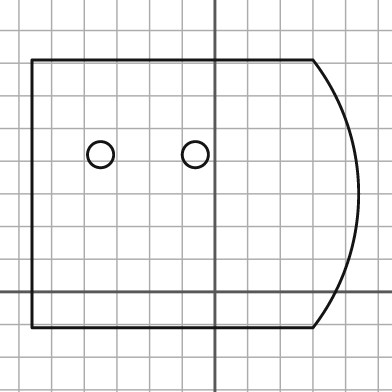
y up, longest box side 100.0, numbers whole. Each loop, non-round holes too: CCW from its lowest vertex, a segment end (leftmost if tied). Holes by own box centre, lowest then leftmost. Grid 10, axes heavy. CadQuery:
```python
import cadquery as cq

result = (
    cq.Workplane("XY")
    .moveTo(-56.0, -11.0)
    .lineTo(30.0, -11.0)
    .threePointArc((44.0, 30.0), (30.0, 71.0))
    .lineTo(-56.0, 71.0)
    .close()
    .moveTo(-35.0, 42.0)
    .circle(4.0)
    .moveTo(-6.0, 42.0)
    .circle(4.0)
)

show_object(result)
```